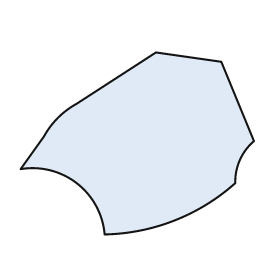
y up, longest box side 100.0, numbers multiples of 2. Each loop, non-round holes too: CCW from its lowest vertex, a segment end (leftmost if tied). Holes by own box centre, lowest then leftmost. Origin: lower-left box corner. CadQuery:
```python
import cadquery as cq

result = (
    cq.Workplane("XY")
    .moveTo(36.0, 0.0)
    .threePointArc((66.0, 6.0), (92.0, 22.0))
    .threePointArc((94.0, 32.0), (100.0, 40.0))
    .lineTo(86.0, 74.0)
    .lineTo(58.0, 78.0)
    .lineTo(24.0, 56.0)
    .threePointArc((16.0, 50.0), (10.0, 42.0))
    .lineTo(0.0, 28.0)
    .threePointArc((24.0, 22.0), (36.0, 0.0))
    .close()
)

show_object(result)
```